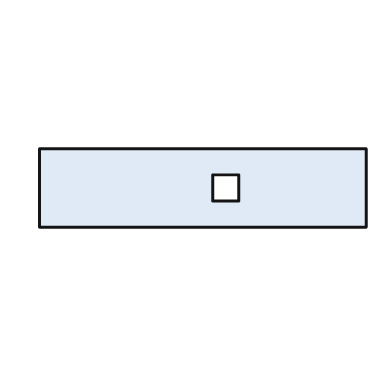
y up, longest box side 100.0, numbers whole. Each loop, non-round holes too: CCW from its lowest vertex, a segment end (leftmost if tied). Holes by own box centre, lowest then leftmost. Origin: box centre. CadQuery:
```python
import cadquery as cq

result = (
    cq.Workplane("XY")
    .moveTo(-50.0, -12.0)
    .lineTo(50.0, -12.0)
    .lineTo(50.0, 12.0)
    .lineTo(-50.0, 12.0)
    .close()
    .moveTo(3.0, -4.0)
    .lineTo(11.0, -4.0)
    .lineTo(11.0, 4.0)
    .lineTo(3.0, 4.0)
    .close()
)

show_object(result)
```